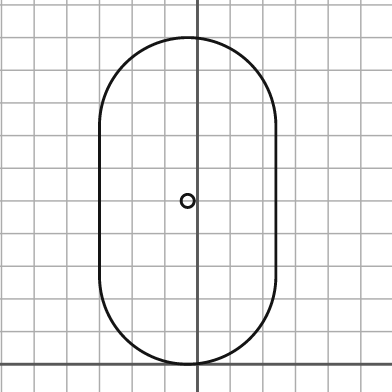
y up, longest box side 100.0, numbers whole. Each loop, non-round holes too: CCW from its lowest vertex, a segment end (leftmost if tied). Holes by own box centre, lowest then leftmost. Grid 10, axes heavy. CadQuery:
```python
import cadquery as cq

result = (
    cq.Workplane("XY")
    .moveTo(-30.0, 27.0)
    .threePointArc((-3.0, 0.0), (24.0, 27.0))
    .lineTo(24.0, 73.0)
    .threePointArc((-3.0, 100.0), (-30.0, 73.0))
    .close()
    .moveTo(-3.0, 50.0)
    .circle(2.0)
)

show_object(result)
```